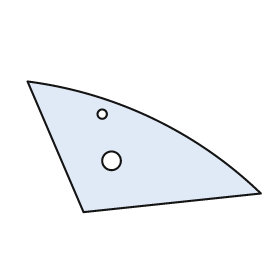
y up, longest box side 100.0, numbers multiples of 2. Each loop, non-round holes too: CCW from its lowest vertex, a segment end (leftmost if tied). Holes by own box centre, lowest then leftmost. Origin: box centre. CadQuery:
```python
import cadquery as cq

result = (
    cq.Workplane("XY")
    .moveTo(-26.0, -28.0)
    .lineTo(50.0, -20.0)
    .threePointArc((4.0, 12.0), (-50.0, 28.0))
    .close()
    .moveTo(-14.0, -6.0)
    .circle(4.0)
    .moveTo(-18.0, 14.0)
    .circle(2.0)
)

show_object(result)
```